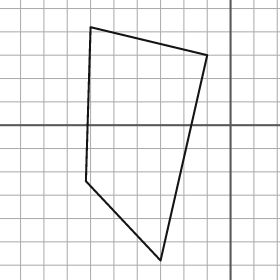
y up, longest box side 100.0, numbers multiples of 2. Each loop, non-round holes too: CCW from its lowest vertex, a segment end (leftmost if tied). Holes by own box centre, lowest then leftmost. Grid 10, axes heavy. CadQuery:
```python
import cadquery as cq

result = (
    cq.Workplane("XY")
    .moveTo(-30.0, -58.0)
    .lineTo(-10.0, 30.0)
    .lineTo(-60.0, 42.0)
    .lineTo(-62.0, -24.0)
    .close()
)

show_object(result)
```